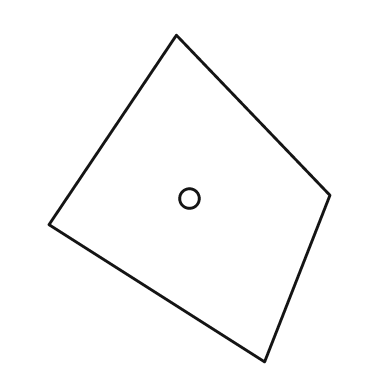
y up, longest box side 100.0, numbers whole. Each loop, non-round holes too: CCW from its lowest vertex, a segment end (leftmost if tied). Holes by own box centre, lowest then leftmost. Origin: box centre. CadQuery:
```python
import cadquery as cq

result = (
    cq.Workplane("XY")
    .moveTo(23.0, -50.0)
    .lineTo(43.0, 1.0)
    .lineTo(-4.0, 50.0)
    .lineTo(-43.0, -8.0)
    .close()
    .moveTo(0.0, 0.0)
    .circle(3.0)
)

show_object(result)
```